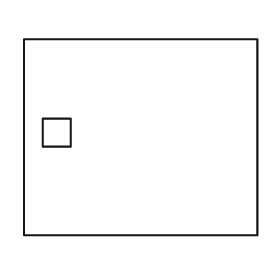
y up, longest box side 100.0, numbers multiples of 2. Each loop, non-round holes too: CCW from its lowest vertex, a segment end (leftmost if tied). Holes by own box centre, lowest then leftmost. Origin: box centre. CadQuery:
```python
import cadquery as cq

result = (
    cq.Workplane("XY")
    .moveTo(-50.0, -42.0)
    .lineTo(50.0, -42.0)
    .lineTo(50.0, 42.0)
    .lineTo(-50.0, 42.0)
    .close()
    .moveTo(-42.0, -4.0)
    .lineTo(-30.0, -4.0)
    .lineTo(-30.0, 8.0)
    .lineTo(-42.0, 8.0)
    .close()
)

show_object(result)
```